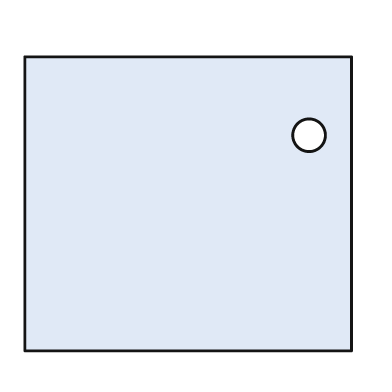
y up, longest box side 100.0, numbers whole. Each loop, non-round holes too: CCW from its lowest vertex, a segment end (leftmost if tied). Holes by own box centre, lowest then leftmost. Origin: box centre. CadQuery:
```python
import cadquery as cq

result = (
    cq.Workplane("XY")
    .moveTo(-50.0, -45.0)
    .lineTo(50.0, -45.0)
    .lineTo(50.0, 45.0)
    .lineTo(-50.0, 45.0)
    .close()
    .moveTo(37.0, 21.0)
    .circle(5.0)
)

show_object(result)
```